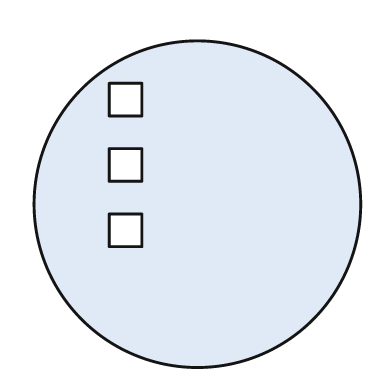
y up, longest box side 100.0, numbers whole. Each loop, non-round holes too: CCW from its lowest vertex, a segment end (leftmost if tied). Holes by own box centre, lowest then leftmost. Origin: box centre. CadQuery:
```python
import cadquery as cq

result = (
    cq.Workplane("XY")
    .moveTo(0.0, 0.0)
    .circle(50.0)
    .moveTo(-27.0, -13.0)
    .lineTo(-17.0, -13.0)
    .lineTo(-17.0, -3.0)
    .lineTo(-27.0, -3.0)
    .close()
    .moveTo(-27.0, 7.0)
    .lineTo(-17.0, 7.0)
    .lineTo(-17.0, 17.0)
    .lineTo(-27.0, 17.0)
    .close()
    .moveTo(-27.0, 27.0)
    .lineTo(-17.0, 27.0)
    .lineTo(-17.0, 37.0)
    .lineTo(-27.0, 37.0)
    .close()
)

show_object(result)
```